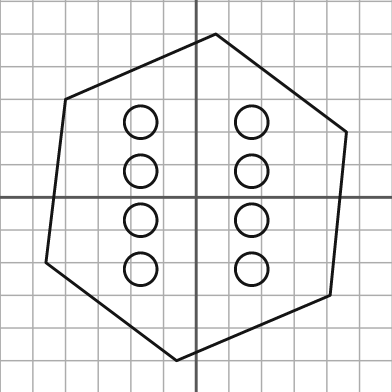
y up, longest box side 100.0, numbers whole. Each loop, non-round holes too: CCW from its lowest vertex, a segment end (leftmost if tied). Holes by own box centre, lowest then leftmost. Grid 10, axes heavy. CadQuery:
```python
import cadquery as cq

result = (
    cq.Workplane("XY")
    .moveTo(-6.0, -50.0)
    .lineTo(41.0, -30.0)
    .lineTo(46.0, 20.0)
    .lineTo(6.0, 50.0)
    .lineTo(-40.0, 30.0)
    .lineTo(-46.0, -20.0)
    .close()
    .moveTo(-17.0, -22.0)
    .circle(5.0)
    .moveTo(17.0, -22.0)
    .circle(5.0)
    .moveTo(-17.0, -7.0)
    .circle(5.0)
    .moveTo(17.0, -7.0)
    .circle(5.0)
    .moveTo(-17.0, 8.0)
    .circle(5.0)
    .moveTo(17.0, 8.0)
    .circle(5.0)
    .moveTo(-17.0, 23.0)
    .circle(5.0)
    .moveTo(17.0, 23.0)
    .circle(5.0)
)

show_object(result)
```